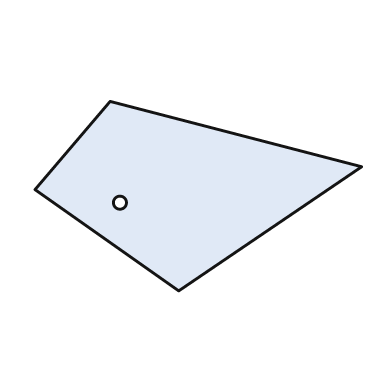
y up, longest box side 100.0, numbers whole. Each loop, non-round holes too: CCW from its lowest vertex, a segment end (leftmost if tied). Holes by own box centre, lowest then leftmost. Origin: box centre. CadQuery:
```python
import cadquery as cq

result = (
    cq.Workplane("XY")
    .moveTo(-6.0, -29.0)
    .lineTo(50.0, 9.0)
    .lineTo(-27.0, 29.0)
    .lineTo(-50.0, 2.0)
    .close()
    .moveTo(-24.0, -2.0)
    .circle(2.0)
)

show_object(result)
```